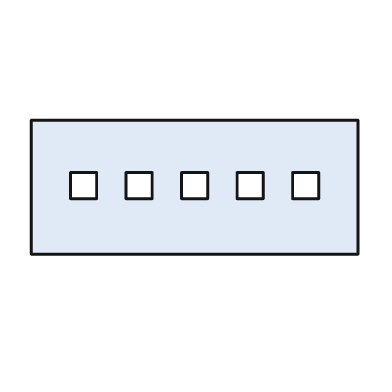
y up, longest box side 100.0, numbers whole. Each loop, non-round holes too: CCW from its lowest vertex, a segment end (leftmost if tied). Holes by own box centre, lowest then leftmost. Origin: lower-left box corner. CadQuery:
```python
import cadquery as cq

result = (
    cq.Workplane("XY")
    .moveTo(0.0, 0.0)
    .lineTo(100.0, 0.0)
    .lineTo(100.0, 41.0)
    .lineTo(0.0, 41.0)
    .close()
    .moveTo(12.0, 17.0)
    .lineTo(20.0, 17.0)
    .lineTo(20.0, 25.0)
    .lineTo(12.0, 25.0)
    .close()
    .moveTo(29.0, 17.0)
    .lineTo(37.0, 17.0)
    .lineTo(37.0, 25.0)
    .lineTo(29.0, 25.0)
    .close()
    .moveTo(46.0, 17.0)
    .lineTo(54.0, 17.0)
    .lineTo(54.0, 25.0)
    .lineTo(46.0, 25.0)
    .close()
    .moveTo(63.0, 17.0)
    .lineTo(71.0, 17.0)
    .lineTo(71.0, 25.0)
    .lineTo(63.0, 25.0)
    .close()
    .moveTo(80.0, 17.0)
    .lineTo(88.0, 17.0)
    .lineTo(88.0, 25.0)
    .lineTo(80.0, 25.0)
    .close()
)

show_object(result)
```